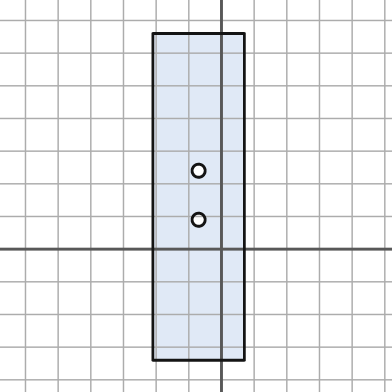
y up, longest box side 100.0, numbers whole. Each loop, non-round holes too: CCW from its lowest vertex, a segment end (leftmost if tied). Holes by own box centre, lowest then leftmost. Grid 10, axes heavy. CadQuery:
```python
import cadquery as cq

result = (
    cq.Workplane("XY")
    .moveTo(-21.0, -34.0)
    .lineTo(7.0, -34.0)
    .lineTo(7.0, 66.0)
    .lineTo(-21.0, 66.0)
    .close()
    .moveTo(-7.0, 9.0)
    .circle(2.0)
    .moveTo(-7.0, 24.0)
    .circle(2.0)
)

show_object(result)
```